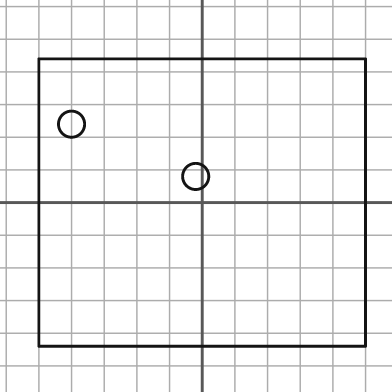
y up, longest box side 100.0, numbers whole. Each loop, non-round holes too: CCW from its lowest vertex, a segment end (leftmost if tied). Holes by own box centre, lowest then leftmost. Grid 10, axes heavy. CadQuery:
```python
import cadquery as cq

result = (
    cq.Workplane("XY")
    .moveTo(-50.0, -44.0)
    .lineTo(50.0, -44.0)
    .lineTo(50.0, 44.0)
    .lineTo(-50.0, 44.0)
    .close()
    .moveTo(-2.0, 8.0)
    .circle(4.0)
    .moveTo(-40.0, 24.0)
    .circle(4.0)
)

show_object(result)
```